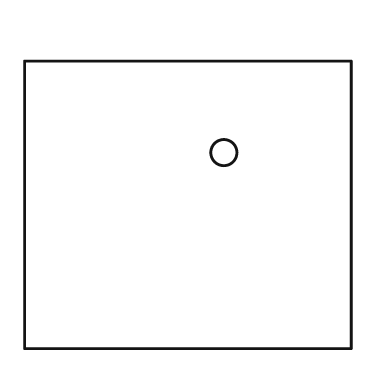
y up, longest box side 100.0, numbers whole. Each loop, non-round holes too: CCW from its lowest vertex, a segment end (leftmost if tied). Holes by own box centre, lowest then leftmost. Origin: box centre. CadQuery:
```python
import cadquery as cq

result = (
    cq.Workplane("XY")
    .moveTo(-50.0, -44.0)
    .lineTo(50.0, -44.0)
    .lineTo(50.0, 44.0)
    .lineTo(-50.0, 44.0)
    .close()
    .moveTo(11.0, 16.0)
    .circle(4.0)
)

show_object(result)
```